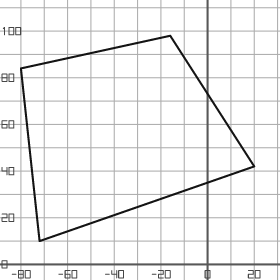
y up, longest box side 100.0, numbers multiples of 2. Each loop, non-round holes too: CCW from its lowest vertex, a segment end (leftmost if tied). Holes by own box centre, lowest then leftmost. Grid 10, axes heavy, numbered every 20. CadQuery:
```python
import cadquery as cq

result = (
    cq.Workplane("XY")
    .moveTo(-72.0, 10.0)
    .lineTo(20.0, 42.0)
    .lineTo(-16.0, 98.0)
    .lineTo(-80.0, 84.0)
    .close()
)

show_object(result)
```